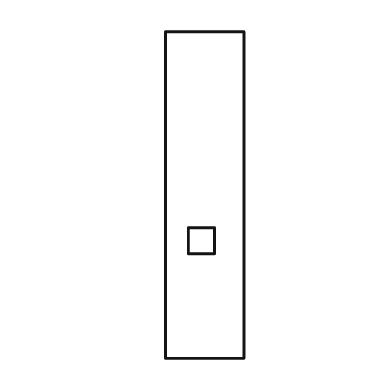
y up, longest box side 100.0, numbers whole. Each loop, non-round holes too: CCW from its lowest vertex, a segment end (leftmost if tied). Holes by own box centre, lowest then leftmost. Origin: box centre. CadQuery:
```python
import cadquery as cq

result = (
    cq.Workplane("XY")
    .moveTo(-12.0, -50.0)
    .lineTo(12.0, -50.0)
    .lineTo(12.0, 50.0)
    .lineTo(-12.0, 50.0)
    .close()
    .moveTo(-5.0, -18.0)
    .lineTo(3.0, -18.0)
    .lineTo(3.0, -10.0)
    .lineTo(-5.0, -10.0)
    .close()
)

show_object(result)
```